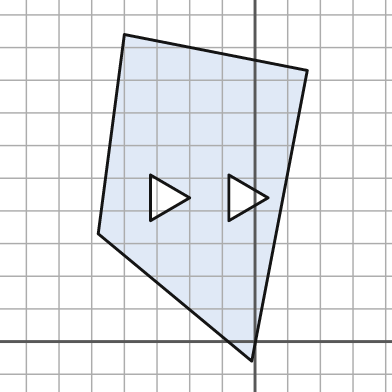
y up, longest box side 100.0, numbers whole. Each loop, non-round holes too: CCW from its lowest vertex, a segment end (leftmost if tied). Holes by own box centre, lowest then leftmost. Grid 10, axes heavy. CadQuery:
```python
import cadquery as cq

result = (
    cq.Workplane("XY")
    .moveTo(-1.0, -6.0)
    .lineTo(16.0, 83.0)
    .lineTo(-40.0, 94.0)
    .lineTo(-48.0, 33.0)
    .close()
    .moveTo(-32.0, 37.0)
    .lineTo(-20.0, 44.0)
    .lineTo(-32.0, 51.0)
    .close()
    .moveTo(-8.0, 37.0)
    .lineTo(4.0, 44.0)
    .lineTo(-8.0, 51.0)
    .close()
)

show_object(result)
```